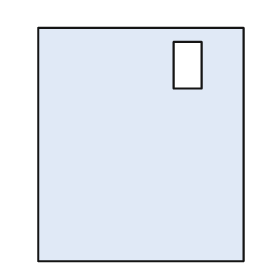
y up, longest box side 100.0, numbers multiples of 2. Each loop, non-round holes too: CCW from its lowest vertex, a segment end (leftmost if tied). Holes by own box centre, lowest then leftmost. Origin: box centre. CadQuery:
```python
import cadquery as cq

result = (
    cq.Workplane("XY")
    .moveTo(-44.0, -50.0)
    .lineTo(44.0, -50.0)
    .lineTo(44.0, 50.0)
    .lineTo(-44.0, 50.0)
    .close()
    .moveTo(14.0, 24.0)
    .lineTo(26.0, 24.0)
    .lineTo(26.0, 44.0)
    .lineTo(14.0, 44.0)
    .close()
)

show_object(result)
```